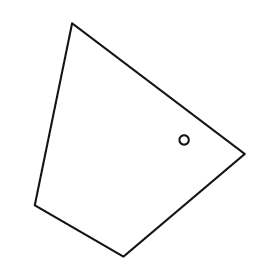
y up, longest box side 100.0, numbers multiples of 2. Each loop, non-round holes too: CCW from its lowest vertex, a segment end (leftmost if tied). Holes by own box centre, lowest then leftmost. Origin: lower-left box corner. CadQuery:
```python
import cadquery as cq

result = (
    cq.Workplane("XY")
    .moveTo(38.0, 0.0)
    .lineTo(90.0, 44.0)
    .lineTo(16.0, 100.0)
    .lineTo(0.0, 22.0)
    .close()
    .moveTo(64.0, 50.0)
    .circle(2.0)
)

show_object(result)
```